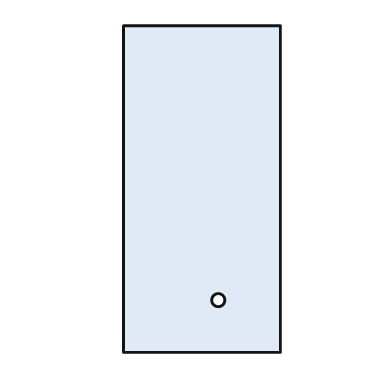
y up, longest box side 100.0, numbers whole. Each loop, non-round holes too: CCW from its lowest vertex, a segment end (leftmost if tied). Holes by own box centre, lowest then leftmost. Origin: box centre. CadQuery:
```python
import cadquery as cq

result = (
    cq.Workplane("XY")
    .moveTo(-24.0, -50.0)
    .lineTo(24.0, -50.0)
    .lineTo(24.0, 50.0)
    .lineTo(-24.0, 50.0)
    .close()
    .moveTo(5.0, -34.0)
    .circle(2.0)
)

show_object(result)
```